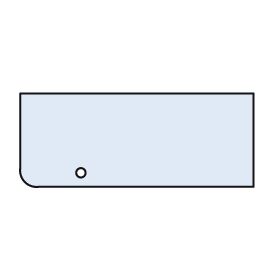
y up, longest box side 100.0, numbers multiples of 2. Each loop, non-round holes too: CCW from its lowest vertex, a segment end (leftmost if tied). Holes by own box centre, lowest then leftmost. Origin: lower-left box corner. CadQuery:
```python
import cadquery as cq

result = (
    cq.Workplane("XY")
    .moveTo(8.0, 0.0)
    .lineTo(100.0, 0.0)
    .lineTo(100.0, 40.0)
    .lineTo(0.0, 40.0)
    .lineTo(0.0, 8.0)
    .threePointArc((2.0, 2.0), (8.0, 0.0))
    .close()
    .moveTo(26.0, 6.0)
    .circle(2.0)
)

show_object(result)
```